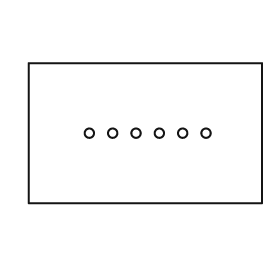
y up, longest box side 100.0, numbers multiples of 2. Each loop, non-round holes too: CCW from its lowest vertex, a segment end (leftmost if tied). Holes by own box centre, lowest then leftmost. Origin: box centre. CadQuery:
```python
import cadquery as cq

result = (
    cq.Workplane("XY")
    .moveTo(-50.0, -30.0)
    .lineTo(50.0, -30.0)
    .lineTo(50.0, 30.0)
    .lineTo(-50.0, 30.0)
    .close()
    .moveTo(-24.0, 0.0)
    .circle(2.0)
    .moveTo(-14.0, 0.0)
    .circle(2.0)
    .moveTo(-4.0, 0.0)
    .circle(2.0)
    .moveTo(6.0, 0.0)
    .circle(2.0)
    .moveTo(16.0, 0.0)
    .circle(2.0)
    .moveTo(26.0, 0.0)
    .circle(2.0)
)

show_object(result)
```